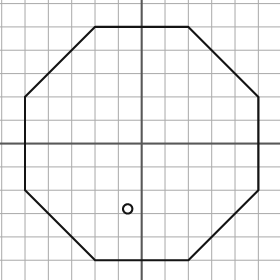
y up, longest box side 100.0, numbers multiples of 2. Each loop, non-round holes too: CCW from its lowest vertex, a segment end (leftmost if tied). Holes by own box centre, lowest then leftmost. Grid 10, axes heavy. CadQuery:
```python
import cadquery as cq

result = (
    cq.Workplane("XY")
    .moveTo(-20.0, -50.0)
    .lineTo(20.0, -50.0)
    .lineTo(50.0, -20.0)
    .lineTo(50.0, 20.0)
    .lineTo(20.0, 50.0)
    .lineTo(-20.0, 50.0)
    .lineTo(-50.0, 20.0)
    .lineTo(-50.0, -20.0)
    .close()
    .moveTo(-6.0, -28.0)
    .circle(2.0)
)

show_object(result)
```